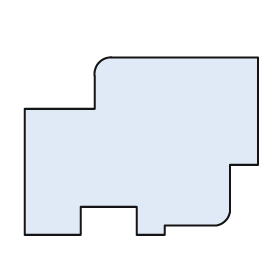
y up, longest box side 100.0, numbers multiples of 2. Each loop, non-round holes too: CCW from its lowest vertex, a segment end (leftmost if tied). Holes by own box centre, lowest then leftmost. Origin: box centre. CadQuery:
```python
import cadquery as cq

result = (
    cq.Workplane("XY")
    .moveTo(-50.0, -38.0)
    .lineTo(-26.0, -38.0)
    .lineTo(-26.0, -26.0)
    .lineTo(-2.0, -26.0)
    .lineTo(-2.0, -38.0)
    .lineTo(10.0, -38.0)
    .lineTo(10.0, -34.0)
    .lineTo(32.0, -34.0)
    .threePointArc((36.0, -32.0), (38.0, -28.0))
    .lineTo(38.0, -8.0)
    .lineTo(50.0, -8.0)
    .lineTo(50.0, 38.0)
    .lineTo(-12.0, 38.0)
    .threePointArc((-18.0, 36.0), (-20.0, 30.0))
    .lineTo(-20.0, 16.0)
    .lineTo(-50.0, 16.0)
    .close()
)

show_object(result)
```